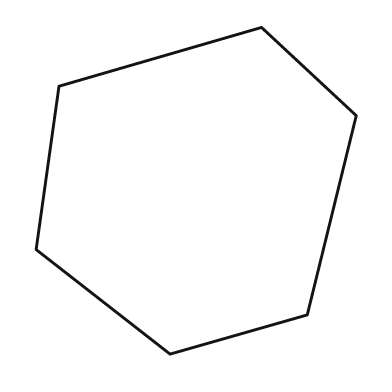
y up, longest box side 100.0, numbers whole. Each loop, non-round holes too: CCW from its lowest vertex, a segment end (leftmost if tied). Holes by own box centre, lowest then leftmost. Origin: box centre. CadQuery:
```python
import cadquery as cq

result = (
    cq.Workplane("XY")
    .moveTo(-8.0, -50.0)
    .lineTo(34.0, -38.0)
    .lineTo(49.0, 23.0)
    .lineTo(20.0, 50.0)
    .lineTo(-42.0, 32.0)
    .lineTo(-49.0, -18.0)
    .close()
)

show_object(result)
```